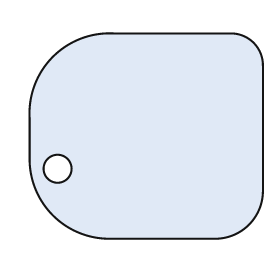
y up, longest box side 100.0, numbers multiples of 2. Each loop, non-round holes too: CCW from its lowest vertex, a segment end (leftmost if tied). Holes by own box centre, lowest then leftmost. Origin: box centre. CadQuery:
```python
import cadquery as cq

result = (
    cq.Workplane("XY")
    .moveTo(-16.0, -44.0)
    .lineTo(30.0, -44.0)
    .threePointArc((44.0, -38.0), (50.0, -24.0))
    .lineTo(50.0, 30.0)
    .threePointArc((46.0, 40.0), (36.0, 44.0))
    .lineTo(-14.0, 44.0)
    .threePointArc((-40.0, 34.0), (-50.0, 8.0))
    .lineTo(-50.0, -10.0)
    .threePointArc((-40.0, -34.0), (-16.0, -44.0))
    .close()
    .moveTo(-38.0, -14.0)
    .circle(6.0)
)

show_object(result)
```